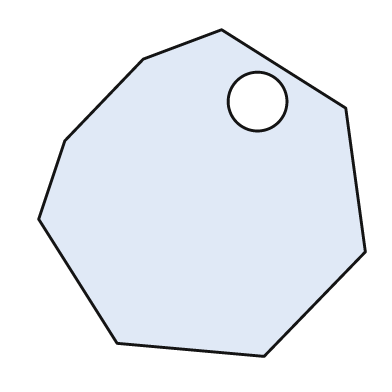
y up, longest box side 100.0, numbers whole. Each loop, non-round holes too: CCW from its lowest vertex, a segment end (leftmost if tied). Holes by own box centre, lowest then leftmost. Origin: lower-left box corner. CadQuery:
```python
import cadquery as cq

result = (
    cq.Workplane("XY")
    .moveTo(69.0, 0.0)
    .lineTo(100.0, 32.0)
    .lineTo(94.0, 76.0)
    .lineTo(56.0, 100.0)
    .lineTo(32.0, 91.0)
    .lineTo(8.0, 66.0)
    .lineTo(0.0, 42.0)
    .lineTo(24.0, 4.0)
    .close()
    .moveTo(67.0, 78.0)
    .circle(9.0)
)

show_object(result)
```